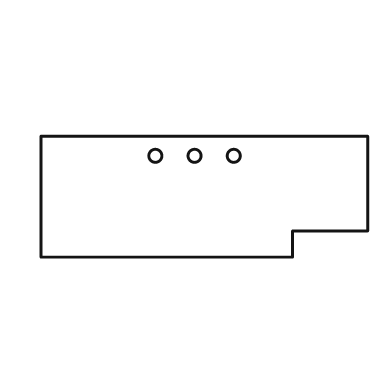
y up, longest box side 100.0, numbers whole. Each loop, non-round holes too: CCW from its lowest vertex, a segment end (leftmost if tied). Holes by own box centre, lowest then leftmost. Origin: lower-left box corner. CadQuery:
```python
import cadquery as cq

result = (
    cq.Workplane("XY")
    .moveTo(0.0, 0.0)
    .lineTo(77.0, 0.0)
    .lineTo(77.0, 8.0)
    .lineTo(100.0, 8.0)
    .lineTo(100.0, 37.0)
    .lineTo(0.0, 37.0)
    .close()
    .moveTo(35.0, 31.0)
    .circle(2.0)
    .moveTo(47.0, 31.0)
    .circle(2.0)
    .moveTo(59.0, 31.0)
    .circle(2.0)
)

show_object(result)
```